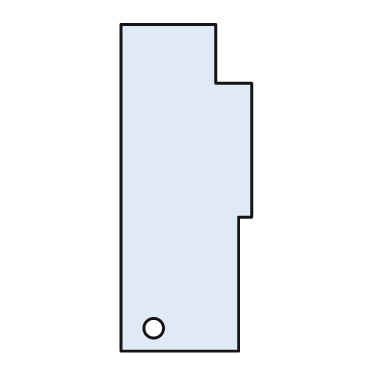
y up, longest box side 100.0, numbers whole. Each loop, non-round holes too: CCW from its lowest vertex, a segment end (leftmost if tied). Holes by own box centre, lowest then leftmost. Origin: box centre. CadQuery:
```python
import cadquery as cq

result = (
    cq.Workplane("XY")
    .moveTo(-20.0, -50.0)
    .lineTo(16.0, -50.0)
    .lineTo(16.0, -9.0)
    .lineTo(20.0, -9.0)
    .lineTo(20.0, 32.0)
    .lineTo(9.0, 32.0)
    .lineTo(9.0, 50.0)
    .lineTo(-20.0, 50.0)
    .close()
    .moveTo(-10.0, -43.0)
    .circle(3.0)
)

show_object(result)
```